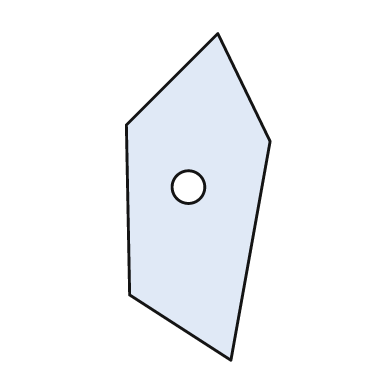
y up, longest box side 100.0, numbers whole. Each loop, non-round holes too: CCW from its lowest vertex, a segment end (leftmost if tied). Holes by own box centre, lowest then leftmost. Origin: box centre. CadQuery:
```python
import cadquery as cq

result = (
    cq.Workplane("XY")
    .moveTo(10.0, -50.0)
    .lineTo(22.0, 17.0)
    .lineTo(6.0, 50.0)
    .lineTo(-22.0, 22.0)
    .lineTo(-21.0, -30.0)
    .close()
    .moveTo(-3.0, 3.0)
    .circle(5.0)
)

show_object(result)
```